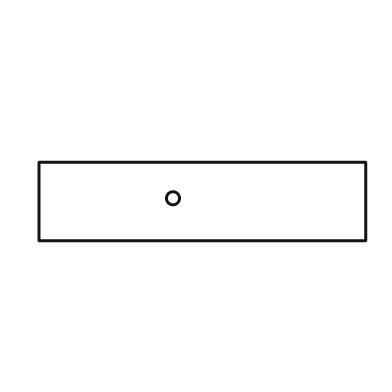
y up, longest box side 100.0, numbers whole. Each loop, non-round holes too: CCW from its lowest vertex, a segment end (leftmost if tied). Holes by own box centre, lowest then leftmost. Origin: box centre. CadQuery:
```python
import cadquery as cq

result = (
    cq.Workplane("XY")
    .moveTo(-50.0, -12.0)
    .lineTo(50.0, -12.0)
    .lineTo(50.0, 12.0)
    .lineTo(-50.0, 12.0)
    .close()
    .moveTo(-9.0, 1.0)
    .circle(2.0)
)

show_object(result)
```